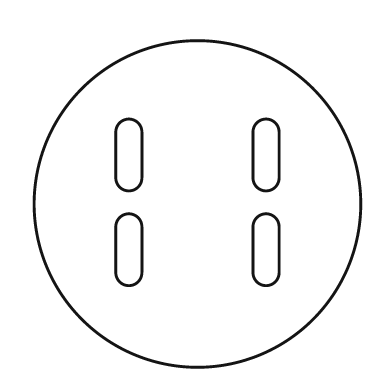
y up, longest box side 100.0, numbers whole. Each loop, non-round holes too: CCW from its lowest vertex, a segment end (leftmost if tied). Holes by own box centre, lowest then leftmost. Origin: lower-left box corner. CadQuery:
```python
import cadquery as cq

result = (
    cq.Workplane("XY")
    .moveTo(50.0, 50.0)
    .circle(50.0)
    .moveTo(25.0, 29.0)
    .threePointArc((29.0, 25.0), (33.0, 29.0))
    .lineTo(33.0, 43.0)
    .threePointArc((29.0, 47.0), (25.0, 43.0))
    .close()
    .moveTo(67.0, 29.0)
    .threePointArc((71.0, 25.0), (75.0, 29.0))
    .lineTo(75.0, 43.0)
    .threePointArc((71.0, 47.0), (67.0, 43.0))
    .close()
    .moveTo(25.0, 58.0)
    .threePointArc((29.0, 54.0), (33.0, 58.0))
    .lineTo(33.0, 72.0)
    .threePointArc((29.0, 76.0), (25.0, 72.0))
    .close()
    .moveTo(67.0, 58.0)
    .threePointArc((71.0, 54.0), (75.0, 58.0))
    .lineTo(75.0, 72.0)
    .threePointArc((71.0, 76.0), (67.0, 72.0))
    .close()
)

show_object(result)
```